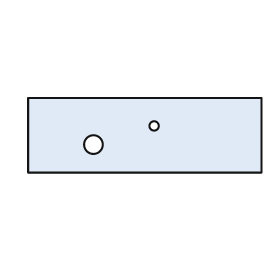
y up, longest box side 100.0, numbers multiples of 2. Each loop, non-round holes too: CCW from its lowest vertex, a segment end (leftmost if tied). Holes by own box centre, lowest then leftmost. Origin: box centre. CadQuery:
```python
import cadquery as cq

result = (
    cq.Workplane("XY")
    .moveTo(-50.0, -16.0)
    .lineTo(50.0, -16.0)
    .lineTo(50.0, 16.0)
    .lineTo(-50.0, 16.0)
    .close()
    .moveTo(-22.0, -4.0)
    .circle(4.0)
    .moveTo(4.0, 4.0)
    .circle(2.0)
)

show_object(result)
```